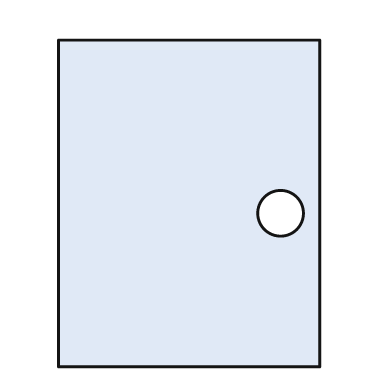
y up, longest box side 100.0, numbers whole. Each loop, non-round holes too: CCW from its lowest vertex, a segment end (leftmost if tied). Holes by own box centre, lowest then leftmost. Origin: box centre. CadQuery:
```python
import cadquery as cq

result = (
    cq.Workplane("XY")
    .moveTo(-40.0, -50.0)
    .lineTo(40.0, -50.0)
    .lineTo(40.0, 50.0)
    .lineTo(-40.0, 50.0)
    .close()
    .moveTo(28.0, -3.0)
    .circle(7.0)
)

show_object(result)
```